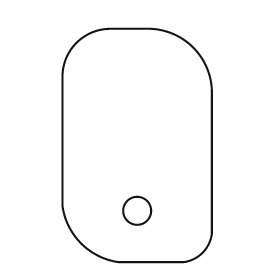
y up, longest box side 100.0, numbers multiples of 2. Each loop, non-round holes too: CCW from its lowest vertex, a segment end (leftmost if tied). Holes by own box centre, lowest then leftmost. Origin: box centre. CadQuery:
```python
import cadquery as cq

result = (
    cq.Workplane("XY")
    .moveTo(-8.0, -50.0)
    .lineTo(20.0, -50.0)
    .threePointArc((28.0, -46.0), (32.0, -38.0))
    .lineTo(32.0, 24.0)
    .threePointArc((24.0, 42.0), (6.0, 50.0))
    .lineTo(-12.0, 50.0)
    .threePointArc((-26.0, 44.0), (-32.0, 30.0))
    .lineTo(-32.0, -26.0)
    .threePointArc((-24.0, -42.0), (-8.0, -50.0))
    .close()
    .moveTo(0.0, -28.0)
    .circle(6.0)
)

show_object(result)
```